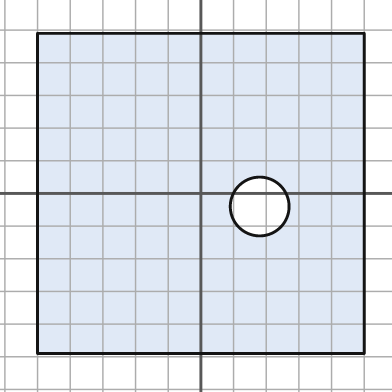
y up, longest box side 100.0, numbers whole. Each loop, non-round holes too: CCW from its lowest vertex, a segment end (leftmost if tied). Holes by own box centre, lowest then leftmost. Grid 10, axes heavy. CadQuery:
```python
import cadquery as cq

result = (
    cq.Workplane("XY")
    .moveTo(-50.0, -49.0)
    .lineTo(50.0, -49.0)
    .lineTo(50.0, 49.0)
    .lineTo(-50.0, 49.0)
    .close()
    .moveTo(18.0, -4.0)
    .circle(9.0)
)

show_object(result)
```